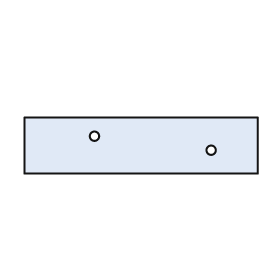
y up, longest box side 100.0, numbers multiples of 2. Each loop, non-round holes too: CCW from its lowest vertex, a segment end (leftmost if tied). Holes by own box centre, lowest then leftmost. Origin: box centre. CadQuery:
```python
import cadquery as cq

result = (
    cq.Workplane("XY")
    .moveTo(-50.0, -12.0)
    .lineTo(50.0, -12.0)
    .lineTo(50.0, 12.0)
    .lineTo(-50.0, 12.0)
    .close()
    .moveTo(30.0, -2.0)
    .circle(2.0)
    .moveTo(-20.0, 4.0)
    .circle(2.0)
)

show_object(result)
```